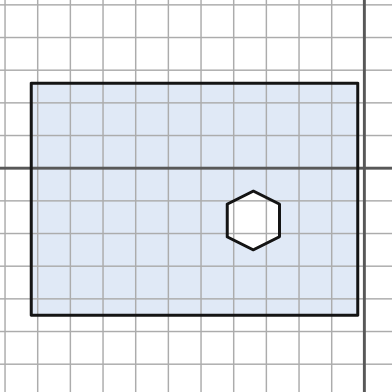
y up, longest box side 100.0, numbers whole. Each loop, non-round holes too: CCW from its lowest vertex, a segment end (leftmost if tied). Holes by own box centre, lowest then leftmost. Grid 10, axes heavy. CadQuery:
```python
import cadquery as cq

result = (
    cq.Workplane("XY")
    .moveTo(-102.0, -45.0)
    .lineTo(-2.0, -45.0)
    .lineTo(-2.0, 26.0)
    .lineTo(-102.0, 26.0)
    .close()
    .moveTo(-34.0, -25.0)
    .lineTo(-26.0, -21.0)
    .lineTo(-26.0, -11.0)
    .lineTo(-34.0, -7.0)
    .lineTo(-42.0, -11.0)
    .lineTo(-42.0, -21.0)
    .close()
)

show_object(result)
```